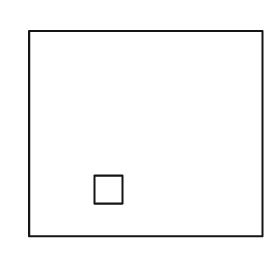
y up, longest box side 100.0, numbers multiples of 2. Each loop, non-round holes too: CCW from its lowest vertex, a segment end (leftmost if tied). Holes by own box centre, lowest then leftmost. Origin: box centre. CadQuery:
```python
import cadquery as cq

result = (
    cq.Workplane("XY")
    .moveTo(-50.0, -44.0)
    .lineTo(50.0, -44.0)
    .lineTo(50.0, 44.0)
    .lineTo(-50.0, 44.0)
    .close()
    .moveTo(-22.0, -30.0)
    .lineTo(-10.0, -30.0)
    .lineTo(-10.0, -18.0)
    .lineTo(-22.0, -18.0)
    .close()
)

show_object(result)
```